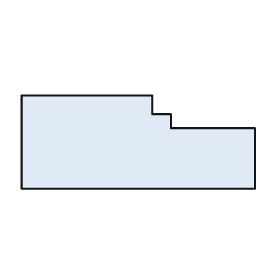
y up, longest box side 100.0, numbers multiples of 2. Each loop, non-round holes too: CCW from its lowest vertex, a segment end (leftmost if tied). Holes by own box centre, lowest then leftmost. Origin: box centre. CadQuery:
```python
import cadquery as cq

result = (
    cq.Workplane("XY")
    .moveTo(-50.0, -20.0)
    .lineTo(50.0, -20.0)
    .lineTo(50.0, 6.0)
    .lineTo(14.0, 6.0)
    .lineTo(14.0, 12.0)
    .lineTo(6.0, 12.0)
    .lineTo(6.0, 20.0)
    .lineTo(-50.0, 20.0)
    .close()
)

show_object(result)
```